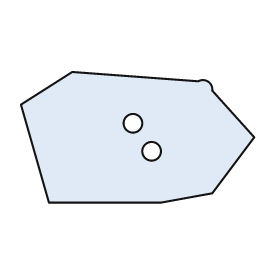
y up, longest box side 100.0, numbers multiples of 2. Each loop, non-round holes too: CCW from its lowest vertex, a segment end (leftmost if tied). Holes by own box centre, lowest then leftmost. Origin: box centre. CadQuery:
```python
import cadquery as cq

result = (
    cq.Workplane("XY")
    .moveTo(-38.0, -28.0)
    .lineTo(10.0, -28.0)
    .lineTo(32.0, -24.0)
    .lineTo(50.0, 0.0)
    .lineTo(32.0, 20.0)
    .threePointArc((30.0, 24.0), (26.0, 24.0))
    .lineTo(-28.0, 28.0)
    .lineTo(-50.0, 14.0)
    .close()
    .moveTo(6.0, -6.0)
    .circle(4.0)
    .moveTo(-2.0, 6.0)
    .circle(4.0)
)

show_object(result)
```